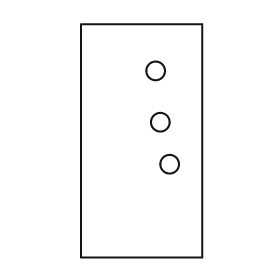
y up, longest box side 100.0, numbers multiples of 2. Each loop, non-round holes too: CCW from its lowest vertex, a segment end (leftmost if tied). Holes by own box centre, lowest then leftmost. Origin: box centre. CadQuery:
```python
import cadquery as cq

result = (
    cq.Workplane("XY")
    .moveTo(-26.0, -50.0)
    .lineTo(26.0, -50.0)
    .lineTo(26.0, 50.0)
    .lineTo(-26.0, 50.0)
    .close()
    .moveTo(12.0, -10.0)
    .circle(4.0)
    .moveTo(8.0, 8.0)
    .circle(4.0)
    .moveTo(6.0, 30.0)
    .circle(4.0)
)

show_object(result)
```